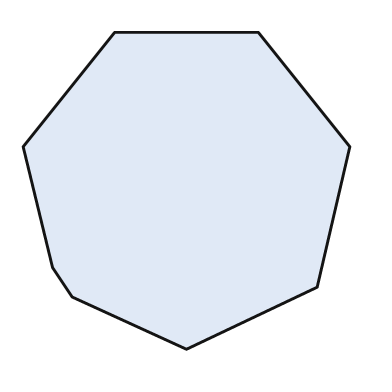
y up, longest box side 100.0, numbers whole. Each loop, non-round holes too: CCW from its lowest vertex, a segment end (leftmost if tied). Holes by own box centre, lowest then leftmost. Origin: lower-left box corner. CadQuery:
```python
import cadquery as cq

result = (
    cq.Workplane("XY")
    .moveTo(50.0, 0.0)
    .lineTo(90.0, 19.0)
    .lineTo(100.0, 62.0)
    .lineTo(72.0, 97.0)
    .lineTo(28.0, 97.0)
    .lineTo(0.0, 62.0)
    .lineTo(9.0, 25.0)
    .lineTo(15.0, 16.0)
    .close()
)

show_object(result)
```